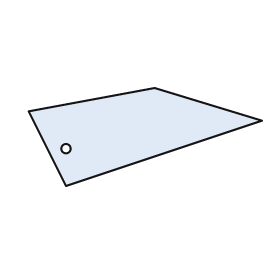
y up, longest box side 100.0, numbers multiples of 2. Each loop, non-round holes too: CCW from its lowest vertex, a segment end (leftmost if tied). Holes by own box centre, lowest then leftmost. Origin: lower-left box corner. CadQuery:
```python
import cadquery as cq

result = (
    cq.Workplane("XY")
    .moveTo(16.0, 0.0)
    .lineTo(100.0, 28.0)
    .lineTo(54.0, 42.0)
    .lineTo(0.0, 32.0)
    .close()
    .moveTo(16.0, 16.0)
    .circle(2.0)
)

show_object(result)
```